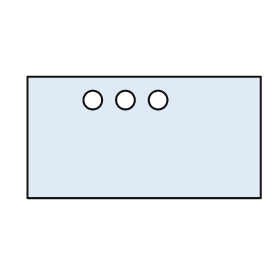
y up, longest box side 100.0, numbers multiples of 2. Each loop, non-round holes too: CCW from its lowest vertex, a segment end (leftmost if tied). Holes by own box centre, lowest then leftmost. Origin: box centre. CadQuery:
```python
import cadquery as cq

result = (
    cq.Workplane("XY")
    .moveTo(-50.0, -26.0)
    .lineTo(50.0, -26.0)
    .lineTo(50.0, 26.0)
    .lineTo(-50.0, 26.0)
    .close()
    .moveTo(-22.0, 16.0)
    .circle(4.0)
    .moveTo(-8.0, 16.0)
    .circle(4.0)
    .moveTo(6.0, 16.0)
    .circle(4.0)
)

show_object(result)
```